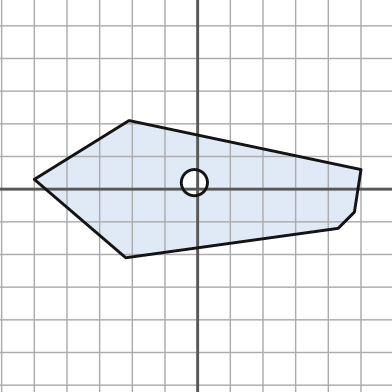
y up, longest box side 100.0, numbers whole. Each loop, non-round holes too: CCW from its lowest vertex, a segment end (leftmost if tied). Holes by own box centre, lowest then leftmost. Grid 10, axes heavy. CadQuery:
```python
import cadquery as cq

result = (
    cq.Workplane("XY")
    .moveTo(-22.0, -21.0)
    .lineTo(43.0, -12.0)
    .lineTo(48.0, -7.0)
    .lineTo(50.0, 6.0)
    .lineTo(-21.0, 21.0)
    .lineTo(-50.0, 3.0)
    .close()
    .moveTo(-1.0, 2.0)
    .circle(4.0)
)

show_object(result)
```